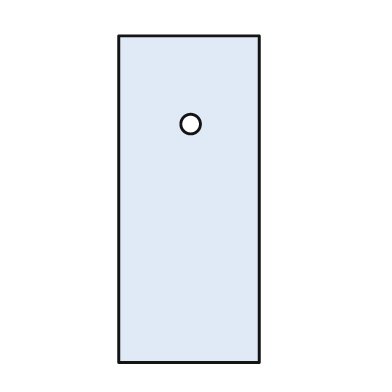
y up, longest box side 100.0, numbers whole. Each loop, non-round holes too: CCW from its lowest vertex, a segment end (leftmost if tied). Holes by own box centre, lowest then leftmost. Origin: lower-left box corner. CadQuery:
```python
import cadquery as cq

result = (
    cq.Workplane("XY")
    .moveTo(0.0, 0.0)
    .lineTo(43.0, 0.0)
    .lineTo(43.0, 100.0)
    .lineTo(0.0, 100.0)
    .close()
    .moveTo(22.0, 73.0)
    .circle(3.0)
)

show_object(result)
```